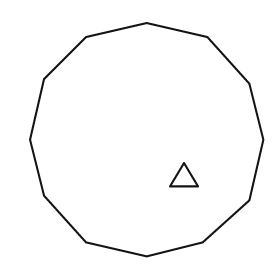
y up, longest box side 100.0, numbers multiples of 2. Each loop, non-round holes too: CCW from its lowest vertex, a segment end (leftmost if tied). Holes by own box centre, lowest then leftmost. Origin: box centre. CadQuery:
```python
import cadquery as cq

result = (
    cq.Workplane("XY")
    .moveTo(0.0, -50.0)
    .lineTo(24.0, -44.0)
    .lineTo(44.0, -26.0)
    .lineTo(50.0, 0.0)
    .lineTo(44.0, 24.0)
    .lineTo(26.0, 44.0)
    .lineTo(0.0, 50.0)
    .lineTo(-26.0, 44.0)
    .lineTo(-44.0, 26.0)
    .lineTo(-50.0, 0.0)
    .lineTo(-44.0, -24.0)
    .lineTo(-26.0, -44.0)
    .close()
    .moveTo(10.0, -20.0)
    .lineTo(22.0, -20.0)
    .lineTo(16.0, -10.0)
    .close()
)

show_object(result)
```